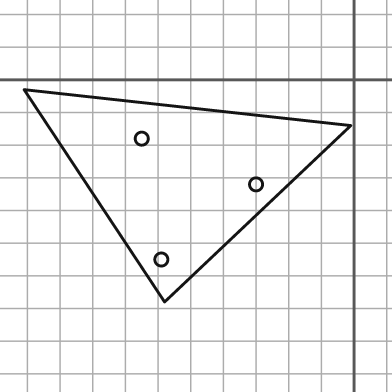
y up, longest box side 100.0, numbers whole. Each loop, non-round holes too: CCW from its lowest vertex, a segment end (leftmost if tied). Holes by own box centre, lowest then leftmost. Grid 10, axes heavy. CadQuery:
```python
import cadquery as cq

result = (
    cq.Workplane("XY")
    .moveTo(-58.0, -68.0)
    .lineTo(-1.0, -14.0)
    .lineTo(-101.0, -3.0)
    .close()
    .moveTo(-59.0, -55.0)
    .circle(2.0)
    .moveTo(-30.0, -32.0)
    .circle(2.0)
    .moveTo(-65.0, -18.0)
    .circle(2.0)
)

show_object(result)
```